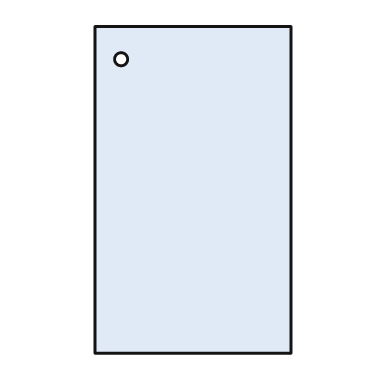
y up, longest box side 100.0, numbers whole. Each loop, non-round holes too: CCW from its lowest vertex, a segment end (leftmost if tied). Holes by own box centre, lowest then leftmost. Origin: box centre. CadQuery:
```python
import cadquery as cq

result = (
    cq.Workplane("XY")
    .moveTo(-30.0, -50.0)
    .lineTo(30.0, -50.0)
    .lineTo(30.0, 50.0)
    .lineTo(-30.0, 50.0)
    .close()
    .moveTo(-22.0, 40.0)
    .circle(2.0)
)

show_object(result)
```